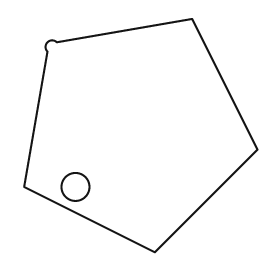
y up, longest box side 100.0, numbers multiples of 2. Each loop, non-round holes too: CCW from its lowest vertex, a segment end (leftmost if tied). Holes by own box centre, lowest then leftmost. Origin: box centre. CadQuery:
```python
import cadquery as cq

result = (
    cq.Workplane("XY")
    .moveTo(6.0, -50.0)
    .lineTo(50.0, -6.0)
    .lineTo(22.0, 50.0)
    .lineTo(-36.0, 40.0)
    .threePointArc((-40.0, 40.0), (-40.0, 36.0))
    .lineTo(-50.0, -22.0)
    .close()
    .moveTo(-28.0, -22.0)
    .circle(6.0)
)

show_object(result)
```